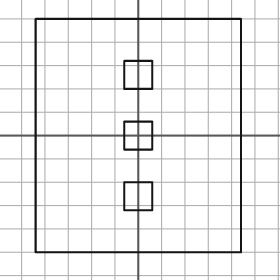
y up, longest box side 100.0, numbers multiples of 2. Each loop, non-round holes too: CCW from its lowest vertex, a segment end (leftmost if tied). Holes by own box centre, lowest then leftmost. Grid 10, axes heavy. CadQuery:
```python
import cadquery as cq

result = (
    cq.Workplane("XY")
    .moveTo(-44.0, -50.0)
    .lineTo(44.0, -50.0)
    .lineTo(44.0, 50.0)
    .lineTo(-44.0, 50.0)
    .close()
    .moveTo(-6.0, -32.0)
    .lineTo(6.0, -32.0)
    .lineTo(6.0, -20.0)
    .lineTo(-6.0, -20.0)
    .close()
    .moveTo(-6.0, -6.0)
    .lineTo(6.0, -6.0)
    .lineTo(6.0, 6.0)
    .lineTo(-6.0, 6.0)
    .close()
    .moveTo(-6.0, 20.0)
    .lineTo(6.0, 20.0)
    .lineTo(6.0, 32.0)
    .lineTo(-6.0, 32.0)
    .close()
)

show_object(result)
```